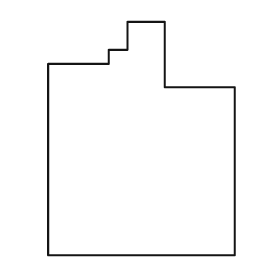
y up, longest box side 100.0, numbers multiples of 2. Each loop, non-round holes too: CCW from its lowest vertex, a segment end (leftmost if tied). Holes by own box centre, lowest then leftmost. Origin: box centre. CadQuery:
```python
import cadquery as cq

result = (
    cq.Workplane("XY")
    .moveTo(-40.0, -50.0)
    .lineTo(40.0, -50.0)
    .lineTo(40.0, 22.0)
    .lineTo(10.0, 22.0)
    .lineTo(10.0, 50.0)
    .lineTo(-6.0, 50.0)
    .lineTo(-6.0, 38.0)
    .lineTo(-14.0, 38.0)
    .lineTo(-14.0, 32.0)
    .lineTo(-40.0, 32.0)
    .close()
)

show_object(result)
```